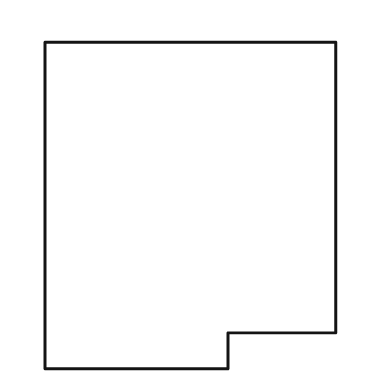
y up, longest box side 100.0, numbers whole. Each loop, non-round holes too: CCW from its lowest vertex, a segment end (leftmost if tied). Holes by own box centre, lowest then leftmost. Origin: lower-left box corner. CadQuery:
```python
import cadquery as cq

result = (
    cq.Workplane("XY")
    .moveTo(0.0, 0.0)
    .lineTo(56.0, 0.0)
    .lineTo(56.0, 11.0)
    .lineTo(89.0, 11.0)
    .lineTo(89.0, 100.0)
    .lineTo(0.0, 100.0)
    .close()
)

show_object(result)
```